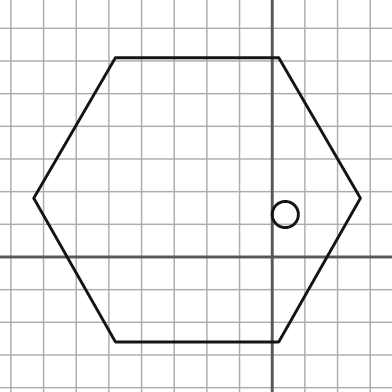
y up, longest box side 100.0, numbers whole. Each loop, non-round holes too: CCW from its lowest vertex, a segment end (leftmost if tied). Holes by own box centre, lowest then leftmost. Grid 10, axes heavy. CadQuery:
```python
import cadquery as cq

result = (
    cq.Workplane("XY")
    .moveTo(-48.0, -26.0)
    .lineTo(2.0, -26.0)
    .lineTo(27.0, 18.0)
    .lineTo(2.0, 61.0)
    .lineTo(-48.0, 61.0)
    .lineTo(-73.0, 18.0)
    .close()
    .moveTo(4.0, 13.0)
    .circle(4.0)
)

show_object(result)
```